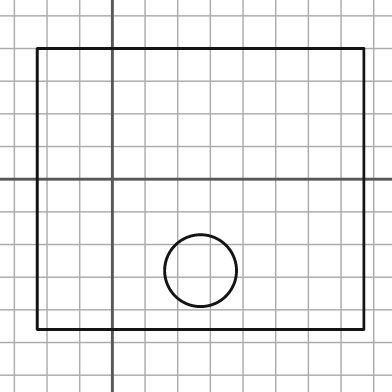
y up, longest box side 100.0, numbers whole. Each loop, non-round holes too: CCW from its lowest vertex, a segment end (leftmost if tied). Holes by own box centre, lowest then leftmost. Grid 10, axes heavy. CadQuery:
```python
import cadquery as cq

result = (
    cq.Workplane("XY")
    .moveTo(-23.0, -46.0)
    .lineTo(77.0, -46.0)
    .lineTo(77.0, 40.0)
    .lineTo(-23.0, 40.0)
    .close()
    .moveTo(27.0, -28.0)
    .circle(11.0)
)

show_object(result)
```